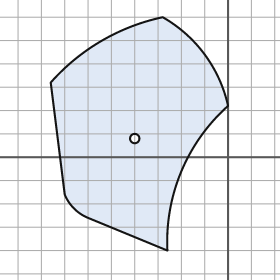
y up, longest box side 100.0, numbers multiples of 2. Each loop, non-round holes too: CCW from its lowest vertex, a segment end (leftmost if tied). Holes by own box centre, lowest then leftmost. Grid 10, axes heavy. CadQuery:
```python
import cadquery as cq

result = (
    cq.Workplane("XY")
    .moveTo(-26.0, -40.0)
    .threePointArc((-20.0, -6.0), (0.0, 22.0))
    .threePointArc((-10.0, 44.0), (-28.0, 60.0))
    .threePointArc((-54.0, 50.0), (-76.0, 32.0))
    .lineTo(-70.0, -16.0)
    .threePointArc((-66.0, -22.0), (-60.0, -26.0))
    .close()
    .moveTo(-40.0, 8.0)
    .circle(2.0)
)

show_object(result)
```